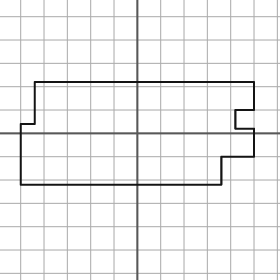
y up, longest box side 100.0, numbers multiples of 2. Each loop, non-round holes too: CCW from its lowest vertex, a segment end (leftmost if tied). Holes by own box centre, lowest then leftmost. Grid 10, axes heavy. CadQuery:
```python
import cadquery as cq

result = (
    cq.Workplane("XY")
    .moveTo(-50.0, -22.0)
    .lineTo(36.0, -22.0)
    .lineTo(36.0, -10.0)
    .lineTo(50.0, -10.0)
    .lineTo(50.0, 2.0)
    .lineTo(42.0, 2.0)
    .lineTo(42.0, 10.0)
    .lineTo(50.0, 10.0)
    .lineTo(50.0, 22.0)
    .lineTo(-44.0, 22.0)
    .lineTo(-44.0, 4.0)
    .lineTo(-50.0, 4.0)
    .close()
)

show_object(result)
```